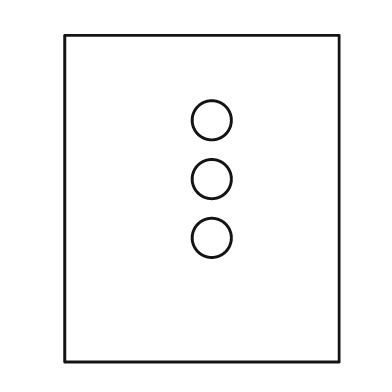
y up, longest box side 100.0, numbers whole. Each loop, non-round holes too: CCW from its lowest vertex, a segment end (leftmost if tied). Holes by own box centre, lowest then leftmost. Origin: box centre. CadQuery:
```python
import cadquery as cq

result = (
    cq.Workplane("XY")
    .moveTo(-42.0, -50.0)
    .lineTo(42.0, -50.0)
    .lineTo(42.0, 50.0)
    .lineTo(-42.0, 50.0)
    .close()
    .moveTo(3.0, -12.0)
    .circle(6.0)
    .moveTo(3.0, 6.0)
    .circle(6.0)
    .moveTo(3.0, 24.0)
    .circle(6.0)
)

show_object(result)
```